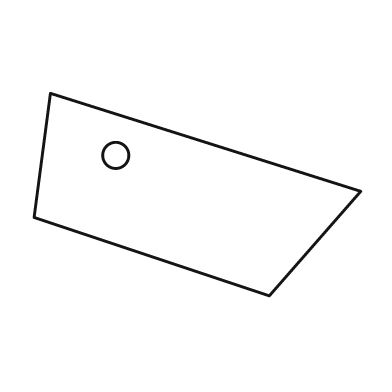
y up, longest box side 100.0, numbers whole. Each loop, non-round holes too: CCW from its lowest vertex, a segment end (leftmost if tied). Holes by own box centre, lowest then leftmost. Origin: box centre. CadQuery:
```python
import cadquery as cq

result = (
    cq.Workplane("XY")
    .moveTo(22.0, -31.0)
    .lineTo(50.0, 1.0)
    .lineTo(-45.0, 31.0)
    .lineTo(-50.0, -7.0)
    .close()
    .moveTo(-25.0, 12.0)
    .circle(4.0)
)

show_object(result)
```